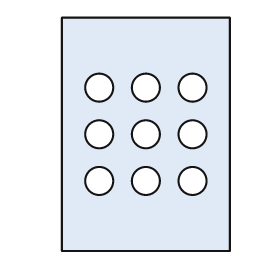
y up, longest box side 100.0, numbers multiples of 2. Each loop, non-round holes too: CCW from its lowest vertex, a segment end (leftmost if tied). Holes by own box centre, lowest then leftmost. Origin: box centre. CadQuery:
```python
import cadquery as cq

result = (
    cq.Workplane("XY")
    .moveTo(-36.0, -50.0)
    .lineTo(36.0, -50.0)
    .lineTo(36.0, 50.0)
    .lineTo(-36.0, 50.0)
    .close()
    .moveTo(-20.0, -20.0)
    .circle(6.0)
    .moveTo(0.0, -20.0)
    .circle(6.0)
    .moveTo(20.0, -20.0)
    .circle(6.0)
    .moveTo(-20.0, 0.0)
    .circle(6.0)
    .moveTo(0.0, 0.0)
    .circle(6.0)
    .moveTo(20.0, 0.0)
    .circle(6.0)
    .moveTo(-20.0, 20.0)
    .circle(6.0)
    .moveTo(0.0, 20.0)
    .circle(6.0)
    .moveTo(20.0, 20.0)
    .circle(6.0)
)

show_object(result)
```